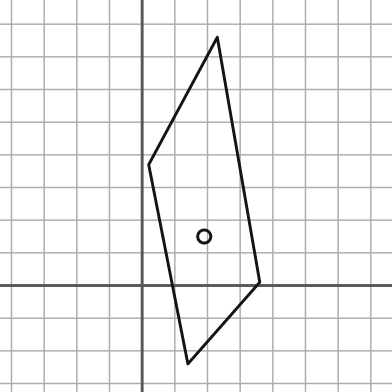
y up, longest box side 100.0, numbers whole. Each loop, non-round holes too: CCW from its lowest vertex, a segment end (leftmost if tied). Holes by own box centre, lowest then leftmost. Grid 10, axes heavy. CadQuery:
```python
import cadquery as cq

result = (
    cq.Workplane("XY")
    .moveTo(14.0, -24.0)
    .lineTo(36.0, 1.0)
    .lineTo(23.0, 76.0)
    .lineTo(2.0, 37.0)
    .close()
    .moveTo(19.0, 15.0)
    .circle(2.0)
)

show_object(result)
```